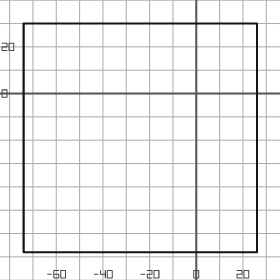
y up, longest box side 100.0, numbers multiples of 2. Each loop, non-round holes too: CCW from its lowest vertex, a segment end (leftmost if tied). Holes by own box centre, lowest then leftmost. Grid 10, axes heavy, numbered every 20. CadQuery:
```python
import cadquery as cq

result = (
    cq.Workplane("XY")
    .moveTo(-74.0, -68.0)
    .lineTo(26.0, -68.0)
    .lineTo(26.0, 30.0)
    .lineTo(-74.0, 30.0)
    .close()
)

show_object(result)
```